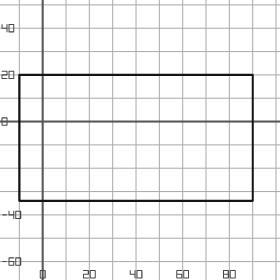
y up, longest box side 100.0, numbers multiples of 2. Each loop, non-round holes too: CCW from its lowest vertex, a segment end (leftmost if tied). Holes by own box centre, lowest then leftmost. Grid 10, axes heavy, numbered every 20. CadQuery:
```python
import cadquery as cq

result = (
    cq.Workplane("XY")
    .moveTo(-10.0, -34.0)
    .lineTo(90.0, -34.0)
    .lineTo(90.0, 20.0)
    .lineTo(-10.0, 20.0)
    .close()
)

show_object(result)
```